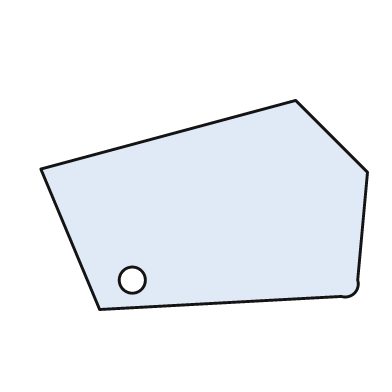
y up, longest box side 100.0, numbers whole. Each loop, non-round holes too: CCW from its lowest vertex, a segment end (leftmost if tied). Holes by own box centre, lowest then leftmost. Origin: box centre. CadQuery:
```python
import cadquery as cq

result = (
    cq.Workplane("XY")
    .moveTo(-32.0, -32.0)
    .lineTo(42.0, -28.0)
    .threePointArc((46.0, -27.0), (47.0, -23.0))
    .lineTo(50.0, 10.0)
    .lineTo(28.0, 32.0)
    .lineTo(-50.0, 11.0)
    .close()
    .moveTo(-22.0, -23.0)
    .circle(4.0)
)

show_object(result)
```